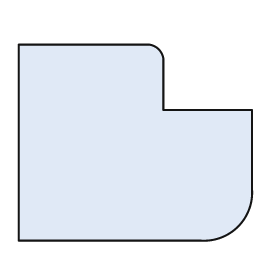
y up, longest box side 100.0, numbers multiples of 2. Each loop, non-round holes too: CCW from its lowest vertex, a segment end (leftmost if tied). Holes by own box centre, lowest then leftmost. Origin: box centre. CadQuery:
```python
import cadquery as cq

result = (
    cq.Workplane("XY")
    .moveTo(-50.0, -42.0)
    .lineTo(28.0, -42.0)
    .threePointArc((44.0, -36.0), (50.0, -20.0))
    .lineTo(50.0, 14.0)
    .lineTo(12.0, 14.0)
    .lineTo(12.0, 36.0)
    .threePointArc((10.0, 40.0), (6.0, 42.0))
    .lineTo(-50.0, 42.0)
    .close()
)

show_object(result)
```